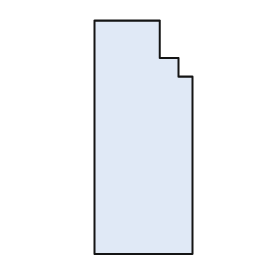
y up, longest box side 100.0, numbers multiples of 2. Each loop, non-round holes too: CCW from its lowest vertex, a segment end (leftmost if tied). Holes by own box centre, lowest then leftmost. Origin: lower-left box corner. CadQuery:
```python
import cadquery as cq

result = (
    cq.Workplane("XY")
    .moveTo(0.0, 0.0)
    .lineTo(42.0, 0.0)
    .lineTo(42.0, 76.0)
    .lineTo(36.0, 76.0)
    .lineTo(36.0, 84.0)
    .lineTo(28.0, 84.0)
    .lineTo(28.0, 100.0)
    .lineTo(0.0, 100.0)
    .close()
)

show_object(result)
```